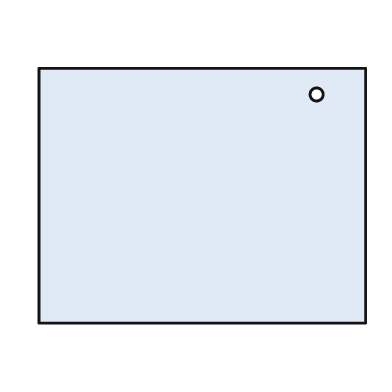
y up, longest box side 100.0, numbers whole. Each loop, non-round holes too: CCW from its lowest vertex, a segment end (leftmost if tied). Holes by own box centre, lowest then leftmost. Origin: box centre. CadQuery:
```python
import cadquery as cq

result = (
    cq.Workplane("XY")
    .moveTo(-50.0, -39.0)
    .lineTo(50.0, -39.0)
    .lineTo(50.0, 39.0)
    .lineTo(-50.0, 39.0)
    .close()
    .moveTo(35.0, 31.0)
    .circle(2.0)
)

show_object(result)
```